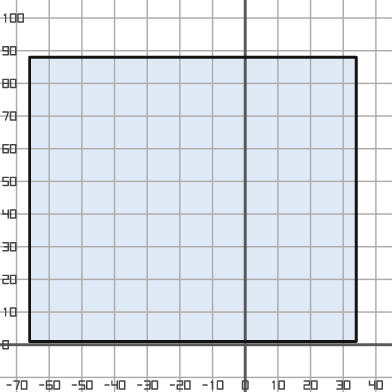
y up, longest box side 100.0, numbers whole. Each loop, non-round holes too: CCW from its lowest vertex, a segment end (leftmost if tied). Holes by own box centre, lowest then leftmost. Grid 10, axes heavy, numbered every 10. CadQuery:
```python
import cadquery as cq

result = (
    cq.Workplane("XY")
    .moveTo(-66.0, 1.0)
    .lineTo(34.0, 1.0)
    .lineTo(34.0, 88.0)
    .lineTo(-66.0, 88.0)
    .close()
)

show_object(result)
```